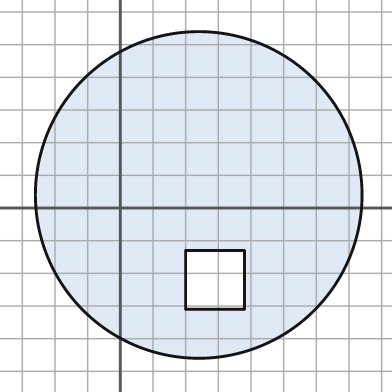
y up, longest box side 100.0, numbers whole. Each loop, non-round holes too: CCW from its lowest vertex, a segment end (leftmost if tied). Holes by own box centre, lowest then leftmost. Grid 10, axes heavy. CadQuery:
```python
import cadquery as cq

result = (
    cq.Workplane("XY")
    .moveTo(24.0, 4.0)
    .circle(50.0)
    .moveTo(20.0, -31.0)
    .lineTo(38.0, -31.0)
    .lineTo(38.0, -13.0)
    .lineTo(20.0, -13.0)
    .close()
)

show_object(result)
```